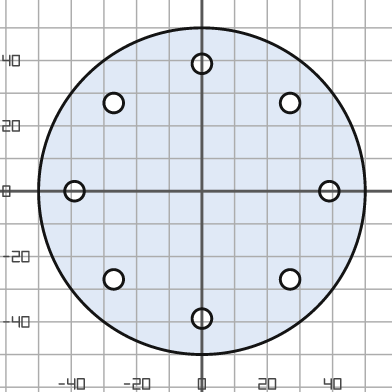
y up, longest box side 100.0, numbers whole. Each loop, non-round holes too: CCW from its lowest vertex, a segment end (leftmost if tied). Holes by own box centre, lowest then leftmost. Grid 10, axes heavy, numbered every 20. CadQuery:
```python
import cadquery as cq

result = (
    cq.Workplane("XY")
    .moveTo(0.0, 0.0)
    .circle(50.0)
    .moveTo(0.0, -39.0)
    .circle(3.0)
    .moveTo(-27.0, -27.0)
    .circle(3.0)
    .moveTo(27.0, -27.0)
    .circle(3.0)
    .moveTo(-39.0, 0.0)
    .circle(3.0)
    .moveTo(39.0, 0.0)
    .circle(3.0)
    .moveTo(-27.0, 27.0)
    .circle(3.0)
    .moveTo(27.0, 27.0)
    .circle(3.0)
    .moveTo(0.0, 39.0)
    .circle(3.0)
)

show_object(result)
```